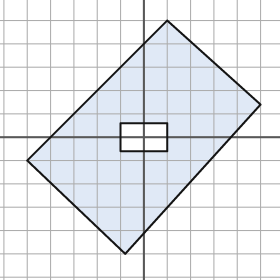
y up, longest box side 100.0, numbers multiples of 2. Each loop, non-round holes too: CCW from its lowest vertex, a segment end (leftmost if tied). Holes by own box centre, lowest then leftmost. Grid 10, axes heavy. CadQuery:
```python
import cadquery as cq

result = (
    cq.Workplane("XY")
    .moveTo(-8.0, -50.0)
    .lineTo(50.0, 14.0)
    .lineTo(10.0, 50.0)
    .lineTo(-50.0, -10.0)
    .close()
    .moveTo(-10.0, -6.0)
    .lineTo(10.0, -6.0)
    .lineTo(10.0, 6.0)
    .lineTo(-10.0, 6.0)
    .close()
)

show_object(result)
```